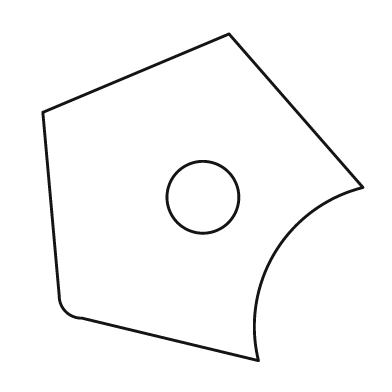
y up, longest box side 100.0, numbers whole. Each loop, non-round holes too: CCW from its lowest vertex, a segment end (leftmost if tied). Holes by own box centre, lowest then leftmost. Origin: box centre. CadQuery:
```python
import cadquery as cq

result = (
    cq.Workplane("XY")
    .moveTo(17.0, -50.0)
    .threePointArc((22.0, -17.0), (49.0, 3.0))
    .lineTo(8.0, 50.0)
    .lineTo(-49.0, 26.0)
    .lineTo(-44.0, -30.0)
    .threePointArc((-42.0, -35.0), (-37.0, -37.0))
    .close()
    .moveTo(0.0, 0.0)
    .circle(11.0)
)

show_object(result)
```